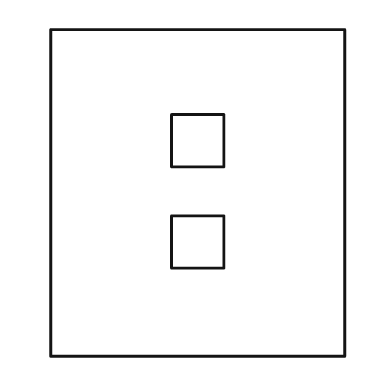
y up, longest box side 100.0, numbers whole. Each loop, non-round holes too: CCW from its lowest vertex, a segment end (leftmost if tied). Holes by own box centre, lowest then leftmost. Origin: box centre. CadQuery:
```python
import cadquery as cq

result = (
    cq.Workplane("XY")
    .moveTo(-45.0, -50.0)
    .lineTo(45.0, -50.0)
    .lineTo(45.0, 50.0)
    .lineTo(-45.0, 50.0)
    .close()
    .moveTo(-8.0, -23.0)
    .lineTo(8.0, -23.0)
    .lineTo(8.0, -7.0)
    .lineTo(-8.0, -7.0)
    .close()
    .moveTo(-8.0, 8.0)
    .lineTo(8.0, 8.0)
    .lineTo(8.0, 24.0)
    .lineTo(-8.0, 24.0)
    .close()
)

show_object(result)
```